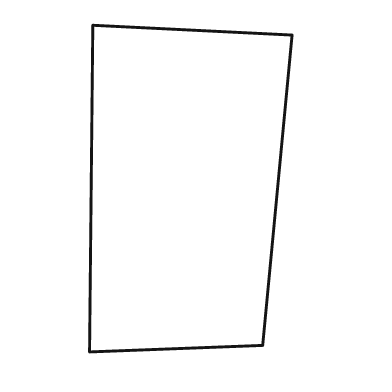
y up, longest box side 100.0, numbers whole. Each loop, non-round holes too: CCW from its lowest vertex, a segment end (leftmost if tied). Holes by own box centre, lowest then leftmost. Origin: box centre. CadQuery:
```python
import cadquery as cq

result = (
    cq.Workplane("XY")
    .moveTo(-31.0, -50.0)
    .lineTo(22.0, -48.0)
    .lineTo(31.0, 47.0)
    .lineTo(-30.0, 50.0)
    .close()
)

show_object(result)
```